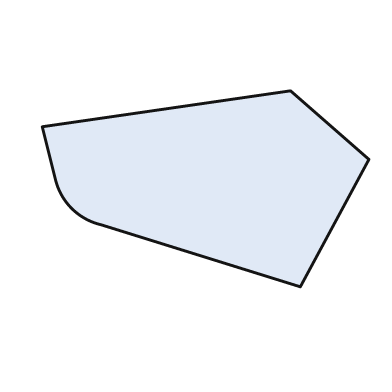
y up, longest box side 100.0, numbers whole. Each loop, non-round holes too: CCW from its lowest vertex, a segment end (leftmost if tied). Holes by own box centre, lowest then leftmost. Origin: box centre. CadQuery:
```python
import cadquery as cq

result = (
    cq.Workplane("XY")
    .moveTo(29.0, -30.0)
    .lineTo(50.0, 9.0)
    .lineTo(26.0, 30.0)
    .lineTo(-50.0, 19.0)
    .lineTo(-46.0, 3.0)
    .threePointArc((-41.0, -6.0), (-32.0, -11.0))
    .close()
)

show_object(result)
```